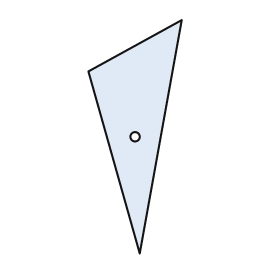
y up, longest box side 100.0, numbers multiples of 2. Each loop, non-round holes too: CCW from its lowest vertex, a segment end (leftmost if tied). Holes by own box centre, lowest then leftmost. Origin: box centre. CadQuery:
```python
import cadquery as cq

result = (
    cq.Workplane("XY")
    .moveTo(2.0, -50.0)
    .lineTo(20.0, 50.0)
    .lineTo(-20.0, 28.0)
    .close()
    .moveTo(0.0, 0.0)
    .circle(2.0)
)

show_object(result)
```